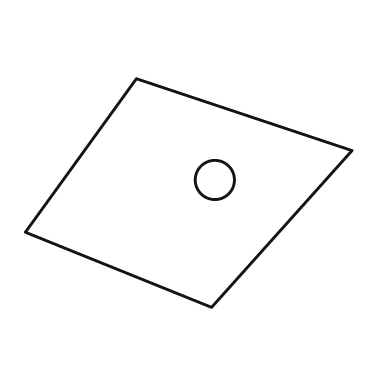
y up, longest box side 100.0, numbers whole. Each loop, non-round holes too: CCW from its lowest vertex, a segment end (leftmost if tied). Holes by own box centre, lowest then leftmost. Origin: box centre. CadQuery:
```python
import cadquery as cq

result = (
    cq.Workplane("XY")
    .moveTo(7.0, -35.0)
    .lineTo(50.0, 13.0)
    .lineTo(-16.0, 35.0)
    .lineTo(-50.0, -12.0)
    .close()
    .moveTo(8.0, 4.0)
    .circle(6.0)
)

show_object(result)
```